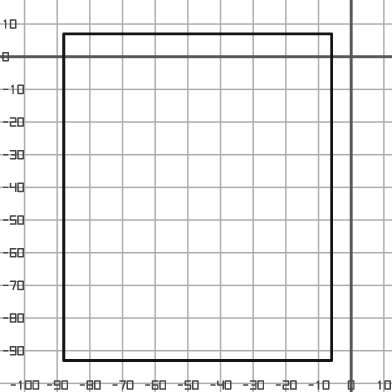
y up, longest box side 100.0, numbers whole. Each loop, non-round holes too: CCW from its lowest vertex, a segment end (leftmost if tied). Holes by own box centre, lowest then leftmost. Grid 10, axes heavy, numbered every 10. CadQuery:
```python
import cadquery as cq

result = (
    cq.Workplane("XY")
    .moveTo(-88.0, -93.0)
    .lineTo(-6.0, -93.0)
    .lineTo(-6.0, 7.0)
    .lineTo(-88.0, 7.0)
    .close()
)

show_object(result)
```